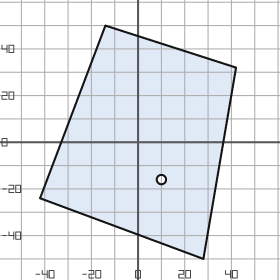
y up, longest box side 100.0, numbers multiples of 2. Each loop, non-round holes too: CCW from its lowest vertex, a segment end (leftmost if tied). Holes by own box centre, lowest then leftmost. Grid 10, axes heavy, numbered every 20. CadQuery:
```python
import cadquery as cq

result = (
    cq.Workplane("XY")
    .moveTo(28.0, -50.0)
    .lineTo(42.0, 32.0)
    .lineTo(-14.0, 50.0)
    .lineTo(-42.0, -24.0)
    .close()
    .moveTo(10.0, -16.0)
    .circle(2.0)
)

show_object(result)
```